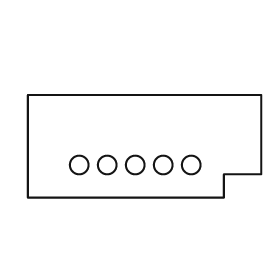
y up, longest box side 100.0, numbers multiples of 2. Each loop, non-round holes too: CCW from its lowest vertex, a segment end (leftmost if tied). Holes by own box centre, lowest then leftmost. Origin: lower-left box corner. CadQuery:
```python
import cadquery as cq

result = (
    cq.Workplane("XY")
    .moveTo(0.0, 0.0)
    .lineTo(84.0, 0.0)
    .lineTo(84.0, 10.0)
    .lineTo(100.0, 10.0)
    .lineTo(100.0, 44.0)
    .lineTo(0.0, 44.0)
    .close()
    .moveTo(22.0, 14.0)
    .circle(4.0)
    .moveTo(34.0, 14.0)
    .circle(4.0)
    .moveTo(46.0, 14.0)
    .circle(4.0)
    .moveTo(58.0, 14.0)
    .circle(4.0)
    .moveTo(70.0, 14.0)
    .circle(4.0)
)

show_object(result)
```